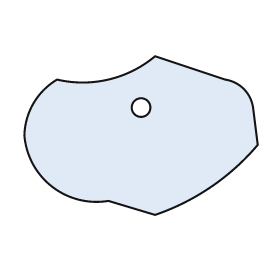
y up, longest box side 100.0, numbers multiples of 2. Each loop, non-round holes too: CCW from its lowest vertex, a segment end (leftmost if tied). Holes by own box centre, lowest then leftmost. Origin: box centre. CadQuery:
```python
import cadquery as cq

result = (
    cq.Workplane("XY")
    .moveTo(6.0, -34.0)
    .threePointArc((30.0, -22.0), (50.0, -4.0))
    .lineTo(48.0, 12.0)
    .threePointArc((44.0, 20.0), (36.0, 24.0))
    .lineTo(6.0, 34.0)
    .threePointArc((-14.0, 24.0), (-36.0, 24.0))
    .threePointArc((-46.0, 14.0), (-50.0, 0.0))
    .threePointArc((-38.0, -22.0), (-14.0, -28.0))
    .close()
    .moveTo(0.0, 12.0)
    .circle(4.0)
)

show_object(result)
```